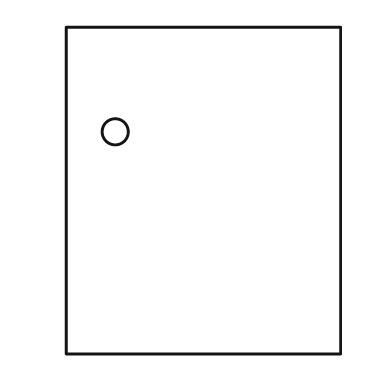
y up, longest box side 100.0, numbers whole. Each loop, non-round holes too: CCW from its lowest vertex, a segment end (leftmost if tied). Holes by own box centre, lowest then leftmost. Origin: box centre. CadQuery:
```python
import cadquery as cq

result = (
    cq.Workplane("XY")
    .moveTo(-42.0, -50.0)
    .lineTo(42.0, -50.0)
    .lineTo(42.0, 50.0)
    .lineTo(-42.0, 50.0)
    .close()
    .moveTo(-27.0, 18.0)
    .circle(4.0)
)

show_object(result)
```